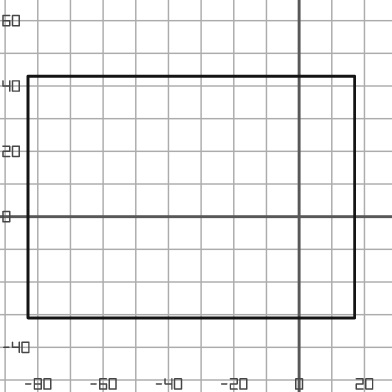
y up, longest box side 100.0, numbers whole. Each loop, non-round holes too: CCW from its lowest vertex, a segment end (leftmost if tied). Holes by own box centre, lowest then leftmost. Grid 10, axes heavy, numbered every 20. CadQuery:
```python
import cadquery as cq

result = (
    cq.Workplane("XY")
    .moveTo(-83.0, -31.0)
    .lineTo(17.0, -31.0)
    .lineTo(17.0, 43.0)
    .lineTo(-83.0, 43.0)
    .close()
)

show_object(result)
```